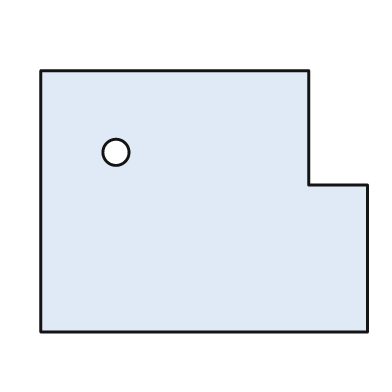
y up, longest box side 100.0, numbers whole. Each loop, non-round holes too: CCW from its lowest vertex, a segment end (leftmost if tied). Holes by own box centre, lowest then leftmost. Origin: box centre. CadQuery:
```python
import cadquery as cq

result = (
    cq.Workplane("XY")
    .moveTo(-50.0, -40.0)
    .lineTo(50.0, -40.0)
    .lineTo(50.0, 5.0)
    .lineTo(32.0, 5.0)
    .lineTo(32.0, 40.0)
    .lineTo(-50.0, 40.0)
    .close()
    .moveTo(-27.0, 15.0)
    .circle(4.0)
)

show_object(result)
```